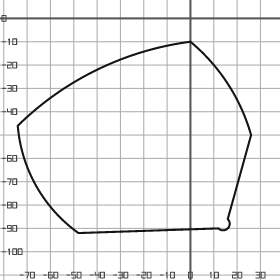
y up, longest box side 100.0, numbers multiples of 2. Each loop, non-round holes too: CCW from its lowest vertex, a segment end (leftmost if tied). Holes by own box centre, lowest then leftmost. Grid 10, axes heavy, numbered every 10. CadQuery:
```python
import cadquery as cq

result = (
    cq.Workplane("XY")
    .moveTo(-48.0, -92.0)
    .lineTo(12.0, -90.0)
    .threePointArc((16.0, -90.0), (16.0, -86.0))
    .lineTo(26.0, -50.0)
    .threePointArc((16.0, -28.0), (0.0, -10.0))
    .threePointArc((-40.0, -22.0), (-74.0, -46.0))
    .threePointArc((-66.0, -72.0), (-48.0, -92.0))
    .close()
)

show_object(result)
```